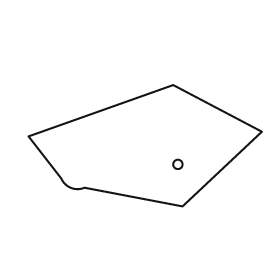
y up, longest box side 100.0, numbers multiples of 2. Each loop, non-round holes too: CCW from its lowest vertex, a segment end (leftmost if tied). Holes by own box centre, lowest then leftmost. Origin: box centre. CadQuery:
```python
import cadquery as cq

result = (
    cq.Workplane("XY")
    .moveTo(16.0, -26.0)
    .lineTo(50.0, 6.0)
    .lineTo(12.0, 26.0)
    .lineTo(-50.0, 4.0)
    .lineTo(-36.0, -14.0)
    .threePointArc((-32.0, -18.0), (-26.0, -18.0))
    .close()
    .moveTo(14.0, -8.0)
    .circle(2.0)
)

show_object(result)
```